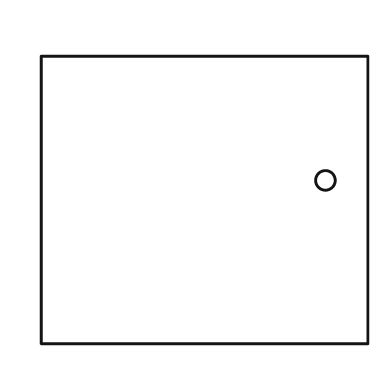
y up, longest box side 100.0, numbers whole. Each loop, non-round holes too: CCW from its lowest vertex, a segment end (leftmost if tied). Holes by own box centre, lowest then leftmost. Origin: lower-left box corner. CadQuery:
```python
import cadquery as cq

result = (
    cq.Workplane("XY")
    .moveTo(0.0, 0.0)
    .lineTo(100.0, 0.0)
    .lineTo(100.0, 88.0)
    .lineTo(0.0, 88.0)
    .close()
    .moveTo(87.0, 50.0)
    .circle(3.0)
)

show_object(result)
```